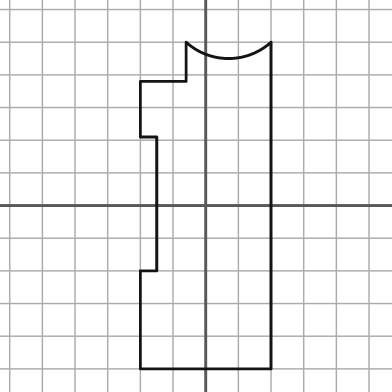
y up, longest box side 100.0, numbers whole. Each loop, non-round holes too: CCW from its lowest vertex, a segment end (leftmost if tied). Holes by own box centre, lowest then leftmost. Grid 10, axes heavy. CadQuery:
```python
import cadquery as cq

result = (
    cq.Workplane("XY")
    .moveTo(-20.0, -50.0)
    .lineTo(20.0, -50.0)
    .lineTo(20.0, 50.0)
    .threePointArc((7.0, 45.0), (-6.0, 50.0))
    .lineTo(-6.0, 38.0)
    .lineTo(-20.0, 38.0)
    .lineTo(-20.0, 21.0)
    .lineTo(-15.0, 21.0)
    .lineTo(-15.0, -20.0)
    .lineTo(-20.0, -20.0)
    .close()
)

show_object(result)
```